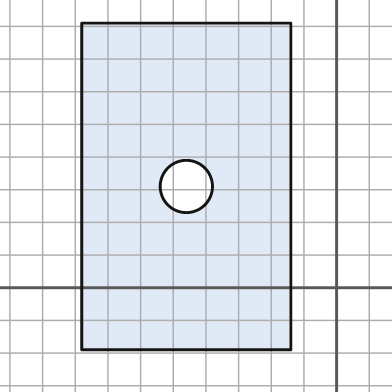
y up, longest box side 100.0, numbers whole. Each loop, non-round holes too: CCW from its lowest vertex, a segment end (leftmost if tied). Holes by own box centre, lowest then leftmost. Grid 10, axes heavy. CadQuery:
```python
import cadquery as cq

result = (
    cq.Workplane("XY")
    .moveTo(-78.0, -19.0)
    .lineTo(-14.0, -19.0)
    .lineTo(-14.0, 81.0)
    .lineTo(-78.0, 81.0)
    .close()
    .moveTo(-46.0, 31.0)
    .circle(8.0)
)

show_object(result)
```